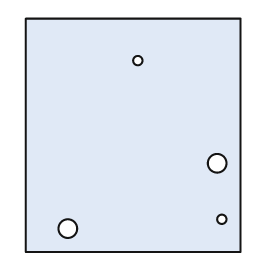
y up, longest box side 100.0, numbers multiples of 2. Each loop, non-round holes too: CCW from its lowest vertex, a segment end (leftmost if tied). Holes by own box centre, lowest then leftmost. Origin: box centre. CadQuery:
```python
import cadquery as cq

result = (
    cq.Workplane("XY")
    .moveTo(-46.0, -50.0)
    .lineTo(46.0, -50.0)
    .lineTo(46.0, 50.0)
    .lineTo(-46.0, 50.0)
    .close()
    .moveTo(-28.0, -40.0)
    .circle(4.0)
    .moveTo(38.0, -36.0)
    .circle(2.0)
    .moveTo(36.0, -12.0)
    .circle(4.0)
    .moveTo(2.0, 32.0)
    .circle(2.0)
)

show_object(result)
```